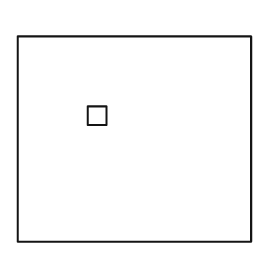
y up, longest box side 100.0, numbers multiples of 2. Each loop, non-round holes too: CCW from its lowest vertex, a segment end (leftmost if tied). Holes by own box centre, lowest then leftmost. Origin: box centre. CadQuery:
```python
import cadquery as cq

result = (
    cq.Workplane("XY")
    .moveTo(-50.0, -44.0)
    .lineTo(50.0, -44.0)
    .lineTo(50.0, 44.0)
    .lineTo(-50.0, 44.0)
    .close()
    .moveTo(-20.0, 6.0)
    .lineTo(-12.0, 6.0)
    .lineTo(-12.0, 14.0)
    .lineTo(-20.0, 14.0)
    .close()
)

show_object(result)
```